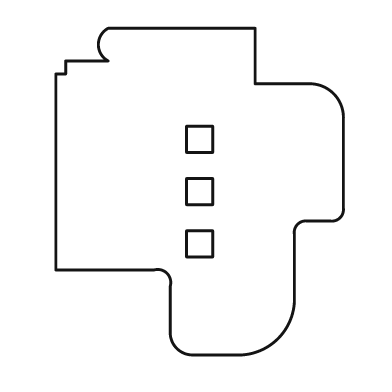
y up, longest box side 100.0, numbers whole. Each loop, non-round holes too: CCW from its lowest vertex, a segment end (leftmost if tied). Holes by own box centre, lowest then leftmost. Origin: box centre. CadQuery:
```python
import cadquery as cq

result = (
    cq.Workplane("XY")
    .moveTo(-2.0, -50.0)
    .lineTo(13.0, -50.0)
    .threePointArc((24.0, -45.0), (29.0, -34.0))
    .lineTo(29.0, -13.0)
    .threePointArc((30.0, -10.0), (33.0, -9.0))
    .lineTo(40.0, -9.0)
    .threePointArc((43.0, -8.0), (44.0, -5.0))
    .lineTo(44.0, 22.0)
    .threePointArc((41.0, 30.0), (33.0, 33.0))
    .lineTo(17.0, 33.0)
    .lineTo(17.0, 50.0)
    .lineTo(-28.0, 50.0)
    .threePointArc((-31.0, 45.0), (-28.0, 40.0))
    .lineTo(-41.0, 40.0)
    .lineTo(-41.0, 36.0)
    .lineTo(-44.0, 36.0)
    .lineTo(-44.0, -24.0)
    .lineTo(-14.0, -24.0)
    .threePointArc((-10.0, -25.0), (-9.0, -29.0))
    .lineTo(-9.0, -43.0)
    .threePointArc((-7.0, -48.0), (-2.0, -50.0))
    .close()
    .moveTo(-4.0, -20.0)
    .lineTo(4.0, -20.0)
    .lineTo(4.0, -12.0)
    .lineTo(-4.0, -12.0)
    .close()
    .moveTo(-4.0, -4.0)
    .lineTo(4.0, -4.0)
    .lineTo(4.0, 4.0)
    .lineTo(-4.0, 4.0)
    .close()
    .moveTo(-4.0, 12.0)
    .lineTo(4.0, 12.0)
    .lineTo(4.0, 20.0)
    .lineTo(-4.0, 20.0)
    .close()
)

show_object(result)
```